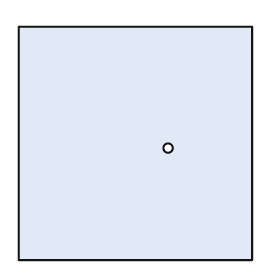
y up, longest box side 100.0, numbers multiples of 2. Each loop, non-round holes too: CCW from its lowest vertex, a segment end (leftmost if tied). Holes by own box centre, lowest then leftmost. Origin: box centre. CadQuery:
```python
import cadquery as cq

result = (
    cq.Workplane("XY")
    .moveTo(-50.0, -50.0)
    .lineTo(50.0, -50.0)
    .lineTo(50.0, 50.0)
    .lineTo(-50.0, 50.0)
    .close()
    .moveTo(14.0, -2.0)
    .circle(2.0)
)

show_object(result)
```